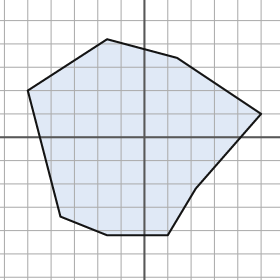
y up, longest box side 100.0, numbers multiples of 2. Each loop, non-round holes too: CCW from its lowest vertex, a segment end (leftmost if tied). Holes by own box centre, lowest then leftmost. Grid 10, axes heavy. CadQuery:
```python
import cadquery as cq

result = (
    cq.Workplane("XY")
    .moveTo(-16.0, -42.0)
    .lineTo(10.0, -42.0)
    .lineTo(22.0, -22.0)
    .lineTo(50.0, 10.0)
    .lineTo(14.0, 34.0)
    .lineTo(-16.0, 42.0)
    .lineTo(-50.0, 20.0)
    .lineTo(-36.0, -34.0)
    .close()
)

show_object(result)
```